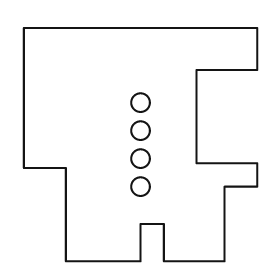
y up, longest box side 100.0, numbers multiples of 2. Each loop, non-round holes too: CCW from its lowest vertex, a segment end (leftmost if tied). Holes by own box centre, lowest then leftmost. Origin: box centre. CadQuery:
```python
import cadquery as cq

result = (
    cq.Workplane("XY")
    .moveTo(-32.0, -50.0)
    .lineTo(0.0, -50.0)
    .lineTo(0.0, -34.0)
    .lineTo(10.0, -34.0)
    .lineTo(10.0, -50.0)
    .lineTo(36.0, -50.0)
    .lineTo(36.0, -18.0)
    .lineTo(50.0, -18.0)
    .lineTo(50.0, -8.0)
    .lineTo(24.0, -8.0)
    .lineTo(24.0, 32.0)
    .lineTo(50.0, 32.0)
    .lineTo(50.0, 50.0)
    .lineTo(-50.0, 50.0)
    .lineTo(-50.0, -10.0)
    .lineTo(-32.0, -10.0)
    .close()
    .moveTo(0.0, -18.0)
    .circle(4.0)
    .moveTo(0.0, -6.0)
    .circle(4.0)
    .moveTo(0.0, 6.0)
    .circle(4.0)
    .moveTo(0.0, 18.0)
    .circle(4.0)
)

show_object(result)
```